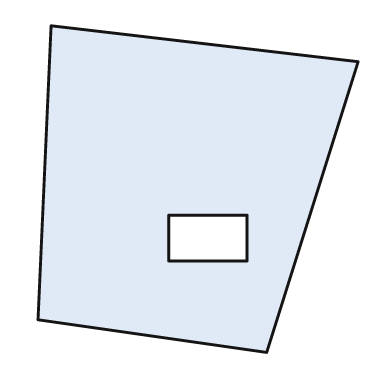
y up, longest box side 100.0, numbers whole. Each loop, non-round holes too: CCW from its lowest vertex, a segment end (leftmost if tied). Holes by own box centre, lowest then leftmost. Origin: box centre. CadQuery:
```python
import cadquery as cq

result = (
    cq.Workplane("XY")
    .moveTo(21.0, -50.0)
    .lineTo(49.0, 39.0)
    .lineTo(-45.0, 50.0)
    .lineTo(-49.0, -40.0)
    .close()
    .moveTo(-9.0, -22.0)
    .lineTo(15.0, -22.0)
    .lineTo(15.0, -8.0)
    .lineTo(-9.0, -8.0)
    .close()
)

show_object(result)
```